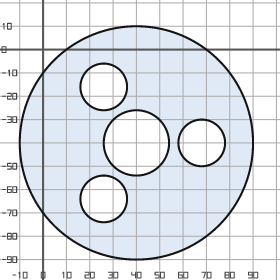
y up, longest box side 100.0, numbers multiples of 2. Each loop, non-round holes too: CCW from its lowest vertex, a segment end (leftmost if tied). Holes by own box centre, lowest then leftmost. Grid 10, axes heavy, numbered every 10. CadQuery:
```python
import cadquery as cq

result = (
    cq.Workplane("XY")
    .moveTo(40.0, -40.0)
    .circle(50.0)
    .moveTo(26.0, -64.0)
    .circle(10.0)
    .moveTo(40.0, -40.0)
    .circle(14.0)
    .moveTo(68.0, -40.0)
    .circle(10.0)
    .moveTo(26.0, -16.0)
    .circle(10.0)
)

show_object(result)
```